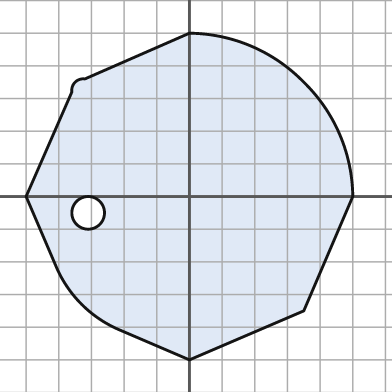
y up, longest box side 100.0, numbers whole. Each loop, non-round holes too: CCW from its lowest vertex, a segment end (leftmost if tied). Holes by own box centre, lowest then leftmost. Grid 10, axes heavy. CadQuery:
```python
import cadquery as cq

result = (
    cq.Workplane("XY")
    .moveTo(0.0, -50.0)
    .lineTo(35.0, -35.0)
    .lineTo(50.0, 0.0)
    .threePointArc((46.0, 19.0), (35.0, 35.0))
    .threePointArc((19.0, 46.0), (0.0, 50.0))
    .lineTo(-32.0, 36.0)
    .threePointArc((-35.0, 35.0), (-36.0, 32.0))
    .lineTo(-50.0, 0.0)
    .lineTo(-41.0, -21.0)
    .threePointArc((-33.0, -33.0), (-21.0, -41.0))
    .close()
    .moveTo(-31.0, -5.0)
    .circle(5.0)
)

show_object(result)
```